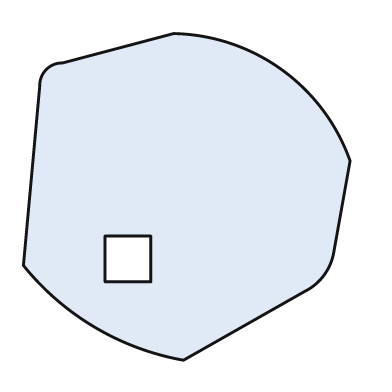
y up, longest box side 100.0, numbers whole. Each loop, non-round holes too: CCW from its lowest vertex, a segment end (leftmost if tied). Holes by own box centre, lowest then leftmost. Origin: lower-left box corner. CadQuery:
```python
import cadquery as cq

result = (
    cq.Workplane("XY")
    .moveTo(49.0, 0.0)
    .lineTo(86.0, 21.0)
    .threePointArc((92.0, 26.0), (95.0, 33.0))
    .lineTo(100.0, 61.0)
    .threePointArc((79.0, 89.0), (46.0, 100.0))
    .lineTo(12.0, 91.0)
    .threePointArc((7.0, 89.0), (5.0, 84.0))
    .lineTo(0.0, 29.0)
    .threePointArc((22.0, 10.0), (49.0, 0.0))
    .close()
    .moveTo(25.0, 24.0)
    .lineTo(39.0, 24.0)
    .lineTo(39.0, 38.0)
    .lineTo(25.0, 38.0)
    .close()
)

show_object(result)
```